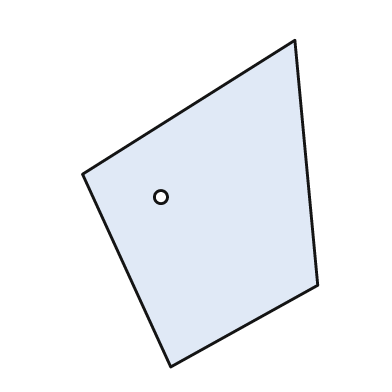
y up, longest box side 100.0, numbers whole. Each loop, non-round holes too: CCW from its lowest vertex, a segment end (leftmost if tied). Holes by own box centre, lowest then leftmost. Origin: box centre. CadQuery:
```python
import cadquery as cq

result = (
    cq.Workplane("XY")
    .moveTo(-9.0, -50.0)
    .lineTo(36.0, -25.0)
    .lineTo(29.0, 50.0)
    .lineTo(-36.0, 9.0)
    .close()
    .moveTo(-12.0, 2.0)
    .circle(2.0)
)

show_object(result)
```